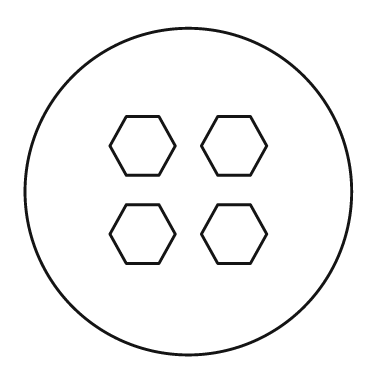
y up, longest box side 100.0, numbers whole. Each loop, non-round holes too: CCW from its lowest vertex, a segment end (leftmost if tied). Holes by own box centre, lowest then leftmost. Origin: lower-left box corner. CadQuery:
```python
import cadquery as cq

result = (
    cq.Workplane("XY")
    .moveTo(50.0, 50.0)
    .circle(50.0)
    .moveTo(31.0, 28.0)
    .lineTo(41.0, 28.0)
    .lineTo(46.0, 37.0)
    .lineTo(41.0, 46.0)
    .lineTo(31.0, 46.0)
    .lineTo(26.0, 37.0)
    .close()
    .moveTo(59.0, 28.0)
    .lineTo(69.0, 28.0)
    .lineTo(74.0, 37.0)
    .lineTo(69.0, 46.0)
    .lineTo(59.0, 46.0)
    .lineTo(54.0, 37.0)
    .close()
    .moveTo(31.0, 55.0)
    .lineTo(41.0, 55.0)
    .lineTo(46.0, 64.0)
    .lineTo(41.0, 73.0)
    .lineTo(31.0, 73.0)
    .lineTo(26.0, 64.0)
    .close()
    .moveTo(59.0, 55.0)
    .lineTo(69.0, 55.0)
    .lineTo(74.0, 64.0)
    .lineTo(69.0, 73.0)
    .lineTo(59.0, 73.0)
    .lineTo(54.0, 64.0)
    .close()
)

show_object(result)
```